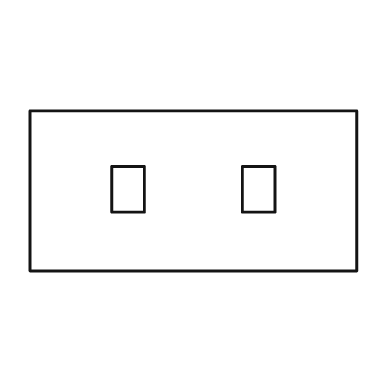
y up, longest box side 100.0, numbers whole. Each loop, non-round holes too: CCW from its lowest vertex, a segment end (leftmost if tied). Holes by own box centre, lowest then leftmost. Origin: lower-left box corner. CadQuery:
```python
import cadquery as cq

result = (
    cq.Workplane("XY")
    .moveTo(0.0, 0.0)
    .lineTo(100.0, 0.0)
    .lineTo(100.0, 49.0)
    .lineTo(0.0, 49.0)
    .close()
    .moveTo(25.0, 18.0)
    .lineTo(35.0, 18.0)
    .lineTo(35.0, 32.0)
    .lineTo(25.0, 32.0)
    .close()
    .moveTo(65.0, 18.0)
    .lineTo(75.0, 18.0)
    .lineTo(75.0, 32.0)
    .lineTo(65.0, 32.0)
    .close()
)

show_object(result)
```